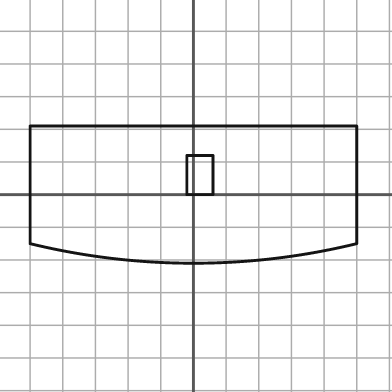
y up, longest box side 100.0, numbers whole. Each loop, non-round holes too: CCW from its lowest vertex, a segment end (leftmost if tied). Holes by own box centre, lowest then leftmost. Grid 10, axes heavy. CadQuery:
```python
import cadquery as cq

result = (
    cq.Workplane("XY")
    .moveTo(-50.0, -15.0)
    .threePointArc((0.0, -21.0), (50.0, -15.0))
    .lineTo(50.0, 21.0)
    .lineTo(-50.0, 21.0)
    .close()
    .moveTo(-2.0, 0.0)
    .lineTo(6.0, 0.0)
    .lineTo(6.0, 12.0)
    .lineTo(-2.0, 12.0)
    .close()
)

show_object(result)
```